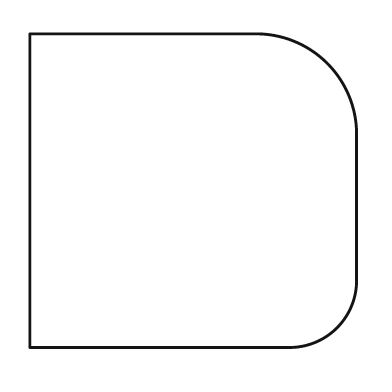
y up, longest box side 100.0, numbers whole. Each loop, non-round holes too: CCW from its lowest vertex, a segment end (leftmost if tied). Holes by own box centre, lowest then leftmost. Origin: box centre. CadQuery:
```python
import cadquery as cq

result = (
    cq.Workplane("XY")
    .moveTo(-50.0, -48.0)
    .lineTo(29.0, -48.0)
    .threePointArc((44.0, -42.0), (50.0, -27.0))
    .lineTo(50.0, 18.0)
    .threePointArc((41.0, 39.0), (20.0, 48.0))
    .lineTo(-50.0, 48.0)
    .close()
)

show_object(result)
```